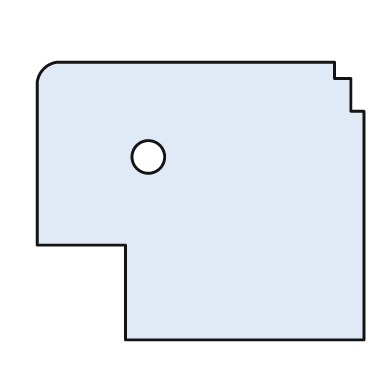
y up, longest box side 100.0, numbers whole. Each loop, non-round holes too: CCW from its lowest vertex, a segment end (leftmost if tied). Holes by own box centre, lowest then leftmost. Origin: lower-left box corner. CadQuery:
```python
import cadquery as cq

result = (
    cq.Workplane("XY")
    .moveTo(27.0, 0.0)
    .lineTo(100.0, 0.0)
    .lineTo(100.0, 70.0)
    .lineTo(96.0, 70.0)
    .lineTo(96.0, 80.0)
    .lineTo(91.0, 80.0)
    .lineTo(91.0, 85.0)
    .lineTo(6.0, 85.0)
    .threePointArc((2.0, 83.0), (0.0, 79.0))
    .lineTo(0.0, 29.0)
    .lineTo(27.0, 29.0)
    .close()
    .moveTo(34.0, 56.0)
    .circle(5.0)
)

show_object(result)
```